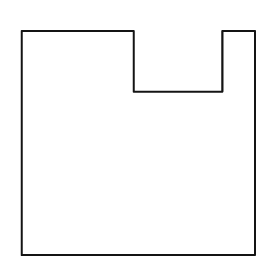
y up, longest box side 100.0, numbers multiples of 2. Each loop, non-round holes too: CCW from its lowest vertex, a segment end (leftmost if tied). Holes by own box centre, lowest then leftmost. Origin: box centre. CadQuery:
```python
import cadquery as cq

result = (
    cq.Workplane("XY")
    .moveTo(-50.0, -48.0)
    .lineTo(50.0, -48.0)
    .lineTo(50.0, 48.0)
    .lineTo(36.0, 48.0)
    .lineTo(36.0, 22.0)
    .lineTo(-2.0, 22.0)
    .lineTo(-2.0, 48.0)
    .lineTo(-50.0, 48.0)
    .close()
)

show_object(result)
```